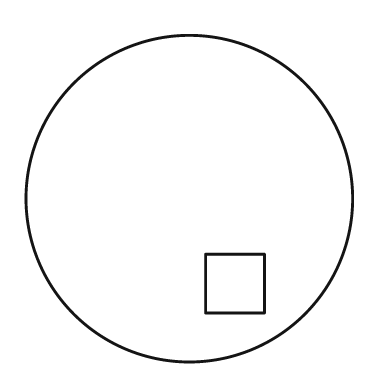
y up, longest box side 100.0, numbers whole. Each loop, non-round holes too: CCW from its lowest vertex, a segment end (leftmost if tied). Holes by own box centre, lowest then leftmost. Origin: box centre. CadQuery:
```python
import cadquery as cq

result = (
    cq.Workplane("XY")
    .moveTo(0.0, 0.0)
    .circle(50.0)
    .moveTo(5.0, -35.0)
    .lineTo(23.0, -35.0)
    .lineTo(23.0, -17.0)
    .lineTo(5.0, -17.0)
    .close()
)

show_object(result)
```